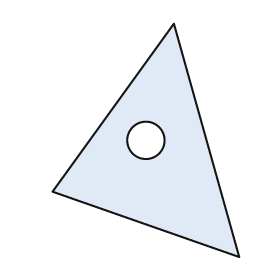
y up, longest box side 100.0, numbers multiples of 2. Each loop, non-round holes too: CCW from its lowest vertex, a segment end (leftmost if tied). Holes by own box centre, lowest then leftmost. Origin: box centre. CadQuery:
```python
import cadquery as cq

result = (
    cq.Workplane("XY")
    .moveTo(40.0, -50.0)
    .lineTo(12.0, 50.0)
    .lineTo(-40.0, -22.0)
    .close()
    .moveTo(0.0, 0.0)
    .circle(8.0)
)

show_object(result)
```